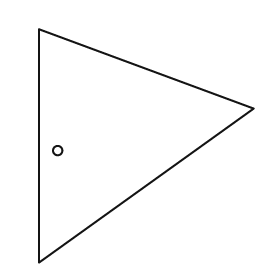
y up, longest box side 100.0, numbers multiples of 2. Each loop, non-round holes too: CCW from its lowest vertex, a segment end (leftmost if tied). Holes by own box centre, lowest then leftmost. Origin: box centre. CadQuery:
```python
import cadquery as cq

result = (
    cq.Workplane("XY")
    .moveTo(-46.0, -50.0)
    .lineTo(46.0, 16.0)
    .lineTo(-46.0, 50.0)
    .close()
    .moveTo(-38.0, -2.0)
    .circle(2.0)
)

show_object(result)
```